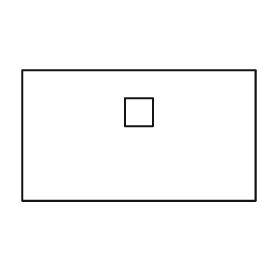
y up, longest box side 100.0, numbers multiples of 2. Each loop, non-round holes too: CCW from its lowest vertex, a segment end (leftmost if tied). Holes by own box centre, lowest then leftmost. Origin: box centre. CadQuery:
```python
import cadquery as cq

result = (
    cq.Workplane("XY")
    .moveTo(-50.0, -28.0)
    .lineTo(50.0, -28.0)
    .lineTo(50.0, 28.0)
    .lineTo(-50.0, 28.0)
    .close()
    .moveTo(-6.0, 4.0)
    .lineTo(6.0, 4.0)
    .lineTo(6.0, 16.0)
    .lineTo(-6.0, 16.0)
    .close()
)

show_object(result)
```